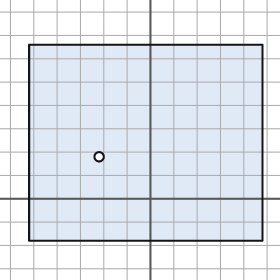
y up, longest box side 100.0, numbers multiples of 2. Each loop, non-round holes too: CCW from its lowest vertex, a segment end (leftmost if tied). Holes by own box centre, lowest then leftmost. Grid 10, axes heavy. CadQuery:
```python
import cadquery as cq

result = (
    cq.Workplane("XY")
    .moveTo(-52.0, -18.0)
    .lineTo(48.0, -18.0)
    .lineTo(48.0, 66.0)
    .lineTo(-52.0, 66.0)
    .close()
    .moveTo(-22.0, 18.0)
    .circle(2.0)
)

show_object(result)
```